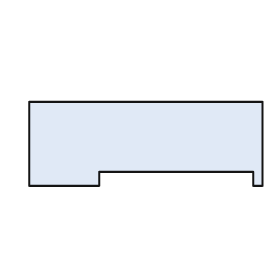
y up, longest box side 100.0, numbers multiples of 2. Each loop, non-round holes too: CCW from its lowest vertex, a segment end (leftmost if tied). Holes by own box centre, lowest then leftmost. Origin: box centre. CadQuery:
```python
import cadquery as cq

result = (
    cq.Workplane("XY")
    .moveTo(-50.0, -18.0)
    .lineTo(-20.0, -18.0)
    .lineTo(-20.0, -12.0)
    .lineTo(46.0, -12.0)
    .lineTo(46.0, -18.0)
    .lineTo(50.0, -18.0)
    .lineTo(50.0, 18.0)
    .lineTo(-50.0, 18.0)
    .close()
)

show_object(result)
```